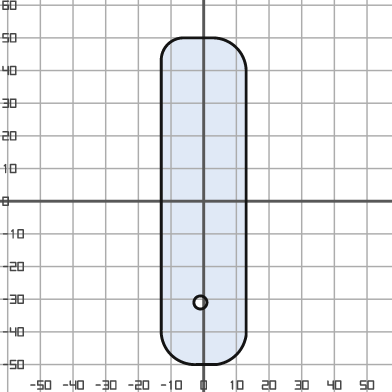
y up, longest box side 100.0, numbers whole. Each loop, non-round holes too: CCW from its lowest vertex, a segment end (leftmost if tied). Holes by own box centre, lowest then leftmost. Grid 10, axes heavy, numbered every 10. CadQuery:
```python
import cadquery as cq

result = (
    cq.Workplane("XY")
    .moveTo(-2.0, -50.0)
    .lineTo(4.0, -50.0)
    .threePointArc((10.0, -47.0), (13.0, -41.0))
    .lineTo(13.0, 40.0)
    .threePointArc((10.0, 47.0), (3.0, 50.0))
    .lineTo(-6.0, 50.0)
    .threePointArc((-11.0, 48.0), (-13.0, 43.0))
    .lineTo(-13.0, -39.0)
    .threePointArc((-10.0, -47.0), (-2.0, -50.0))
    .close()
    .moveTo(-1.0, -31.0)
    .circle(2.0)
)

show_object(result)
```